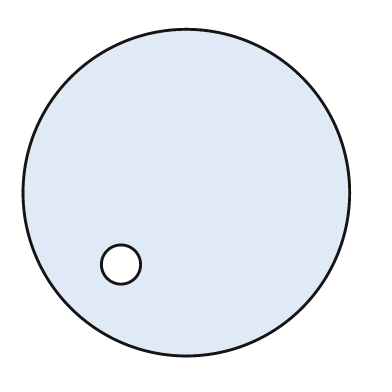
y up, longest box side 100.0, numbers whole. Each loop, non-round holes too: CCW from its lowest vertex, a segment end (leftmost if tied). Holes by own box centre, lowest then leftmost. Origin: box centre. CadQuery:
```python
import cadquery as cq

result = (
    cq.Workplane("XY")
    .moveTo(0.0, 0.0)
    .circle(50.0)
    .moveTo(-20.0, -22.0)
    .circle(6.0)
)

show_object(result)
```